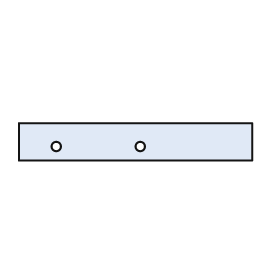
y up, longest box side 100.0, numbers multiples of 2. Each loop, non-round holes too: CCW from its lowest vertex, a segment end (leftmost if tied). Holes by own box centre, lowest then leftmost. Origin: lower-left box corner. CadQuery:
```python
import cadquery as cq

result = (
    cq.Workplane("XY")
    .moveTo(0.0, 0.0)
    .lineTo(100.0, 0.0)
    .lineTo(100.0, 16.0)
    .lineTo(0.0, 16.0)
    .close()
    .moveTo(16.0, 6.0)
    .circle(2.0)
    .moveTo(52.0, 6.0)
    .circle(2.0)
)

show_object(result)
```